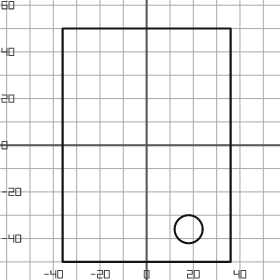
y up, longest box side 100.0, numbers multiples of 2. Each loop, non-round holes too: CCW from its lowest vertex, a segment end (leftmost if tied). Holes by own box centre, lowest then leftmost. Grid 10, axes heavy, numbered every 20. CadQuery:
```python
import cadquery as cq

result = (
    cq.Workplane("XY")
    .moveTo(-36.0, -50.0)
    .lineTo(36.0, -50.0)
    .lineTo(36.0, 50.0)
    .lineTo(-36.0, 50.0)
    .close()
    .moveTo(18.0, -36.0)
    .circle(6.0)
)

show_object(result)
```